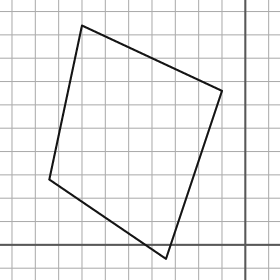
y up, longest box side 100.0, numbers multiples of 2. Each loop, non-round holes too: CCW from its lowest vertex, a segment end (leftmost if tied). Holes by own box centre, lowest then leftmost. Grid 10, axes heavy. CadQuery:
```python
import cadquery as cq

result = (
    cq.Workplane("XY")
    .moveTo(-34.0, -6.0)
    .lineTo(-10.0, 66.0)
    .lineTo(-70.0, 94.0)
    .lineTo(-84.0, 28.0)
    .close()
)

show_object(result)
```